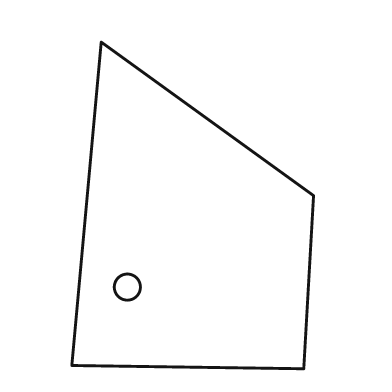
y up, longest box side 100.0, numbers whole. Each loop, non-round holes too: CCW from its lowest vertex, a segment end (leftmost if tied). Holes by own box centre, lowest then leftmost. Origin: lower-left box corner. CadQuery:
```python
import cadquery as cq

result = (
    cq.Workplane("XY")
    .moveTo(71.0, 0.0)
    .lineTo(74.0, 53.0)
    .lineTo(9.0, 100.0)
    .lineTo(0.0, 1.0)
    .close()
    .moveTo(17.0, 25.0)
    .circle(4.0)
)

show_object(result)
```